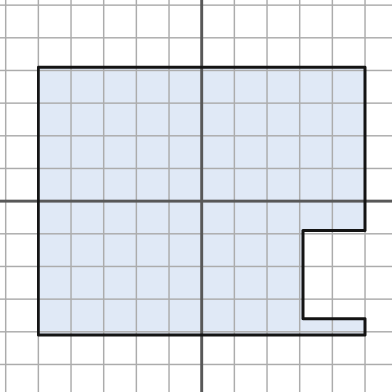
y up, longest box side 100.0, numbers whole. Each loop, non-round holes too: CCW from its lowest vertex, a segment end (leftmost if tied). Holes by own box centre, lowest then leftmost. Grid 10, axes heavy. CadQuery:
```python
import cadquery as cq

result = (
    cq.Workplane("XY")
    .moveTo(-50.0, -41.0)
    .lineTo(50.0, -41.0)
    .lineTo(50.0, -36.0)
    .lineTo(31.0, -36.0)
    .lineTo(31.0, -9.0)
    .lineTo(50.0, -9.0)
    .lineTo(50.0, 41.0)
    .lineTo(-50.0, 41.0)
    .close()
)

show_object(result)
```